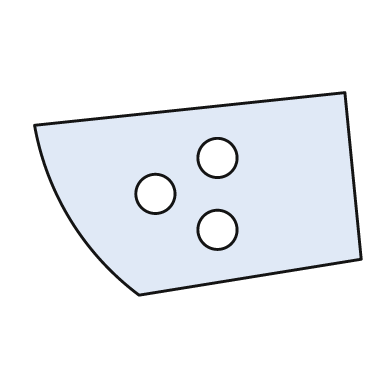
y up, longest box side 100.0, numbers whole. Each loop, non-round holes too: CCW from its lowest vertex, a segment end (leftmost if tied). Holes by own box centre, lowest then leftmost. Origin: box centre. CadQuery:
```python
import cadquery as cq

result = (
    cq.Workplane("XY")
    .moveTo(-18.0, -31.0)
    .lineTo(50.0, -20.0)
    .lineTo(45.0, 31.0)
    .lineTo(-50.0, 21.0)
    .threePointArc((-39.0, -8.0), (-18.0, -31.0))
    .close()
    .moveTo(6.0, -11.0)
    .circle(6.0)
    .moveTo(-13.0, 0.0)
    .circle(6.0)
    .moveTo(6.0, 11.0)
    .circle(6.0)
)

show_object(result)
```